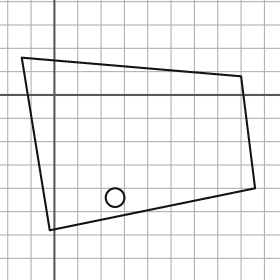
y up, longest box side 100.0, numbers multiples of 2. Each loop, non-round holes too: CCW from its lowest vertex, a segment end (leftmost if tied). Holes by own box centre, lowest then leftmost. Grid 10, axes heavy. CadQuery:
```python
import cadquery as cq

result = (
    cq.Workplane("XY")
    .moveTo(-2.0, -58.0)
    .lineTo(86.0, -40.0)
    .lineTo(80.0, 8.0)
    .lineTo(-14.0, 16.0)
    .close()
    .moveTo(26.0, -44.0)
    .circle(4.0)
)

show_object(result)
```